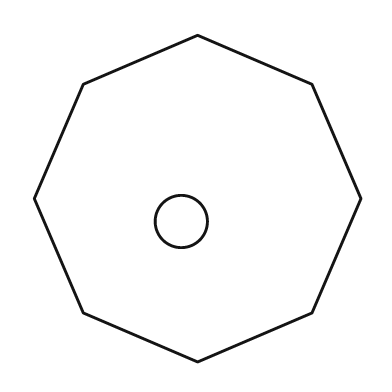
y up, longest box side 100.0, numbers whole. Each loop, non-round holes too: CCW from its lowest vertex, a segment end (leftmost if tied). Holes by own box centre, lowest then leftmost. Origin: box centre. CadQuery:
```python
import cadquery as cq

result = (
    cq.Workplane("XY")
    .moveTo(0.0, -50.0)
    .lineTo(35.0, -35.0)
    .lineTo(50.0, 0.0)
    .lineTo(35.0, 35.0)
    .lineTo(0.0, 50.0)
    .lineTo(-35.0, 35.0)
    .lineTo(-50.0, 0.0)
    .lineTo(-35.0, -35.0)
    .close()
    .moveTo(-5.0, -7.0)
    .circle(8.0)
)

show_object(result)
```